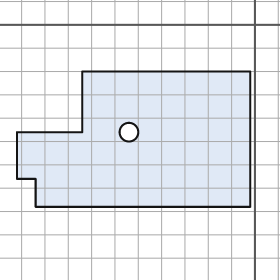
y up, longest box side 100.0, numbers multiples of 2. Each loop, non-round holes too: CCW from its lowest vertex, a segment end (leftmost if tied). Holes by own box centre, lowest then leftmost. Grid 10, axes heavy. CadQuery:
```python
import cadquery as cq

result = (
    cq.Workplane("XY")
    .moveTo(-94.0, -78.0)
    .lineTo(-2.0, -78.0)
    .lineTo(-2.0, -20.0)
    .lineTo(-74.0, -20.0)
    .lineTo(-74.0, -46.0)
    .lineTo(-102.0, -46.0)
    .lineTo(-102.0, -66.0)
    .lineTo(-94.0, -66.0)
    .close()
    .moveTo(-54.0, -46.0)
    .circle(4.0)
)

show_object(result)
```